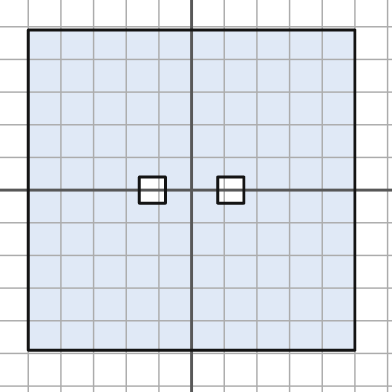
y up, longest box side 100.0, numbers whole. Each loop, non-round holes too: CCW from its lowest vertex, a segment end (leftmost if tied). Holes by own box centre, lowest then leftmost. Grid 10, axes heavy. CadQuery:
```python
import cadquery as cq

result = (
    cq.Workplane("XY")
    .moveTo(-50.0, -49.0)
    .lineTo(50.0, -49.0)
    .lineTo(50.0, 49.0)
    .lineTo(-50.0, 49.0)
    .close()
    .moveTo(-16.0, -4.0)
    .lineTo(-8.0, -4.0)
    .lineTo(-8.0, 4.0)
    .lineTo(-16.0, 4.0)
    .close()
    .moveTo(8.0, -4.0)
    .lineTo(16.0, -4.0)
    .lineTo(16.0, 4.0)
    .lineTo(8.0, 4.0)
    .close()
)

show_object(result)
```